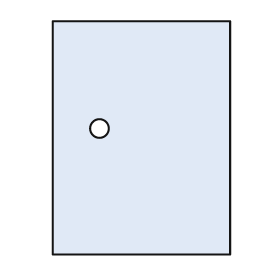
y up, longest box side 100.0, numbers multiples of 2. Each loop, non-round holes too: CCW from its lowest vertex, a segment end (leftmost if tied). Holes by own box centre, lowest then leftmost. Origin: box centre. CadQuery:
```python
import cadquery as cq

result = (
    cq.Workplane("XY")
    .moveTo(-38.0, -50.0)
    .lineTo(38.0, -50.0)
    .lineTo(38.0, 50.0)
    .lineTo(-38.0, 50.0)
    .close()
    .moveTo(-18.0, 4.0)
    .circle(4.0)
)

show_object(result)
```